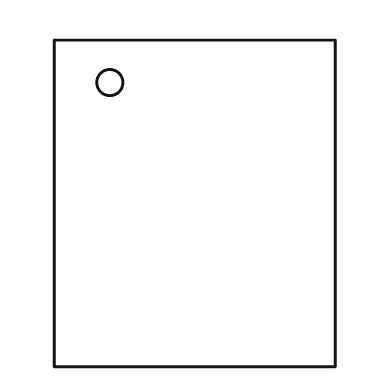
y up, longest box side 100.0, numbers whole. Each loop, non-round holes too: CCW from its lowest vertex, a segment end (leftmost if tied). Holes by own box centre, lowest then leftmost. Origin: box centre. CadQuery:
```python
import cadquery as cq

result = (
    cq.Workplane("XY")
    .moveTo(-43.0, -50.0)
    .lineTo(43.0, -50.0)
    .lineTo(43.0, 50.0)
    .lineTo(-43.0, 50.0)
    .close()
    .moveTo(-26.0, 37.0)
    .circle(4.0)
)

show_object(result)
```